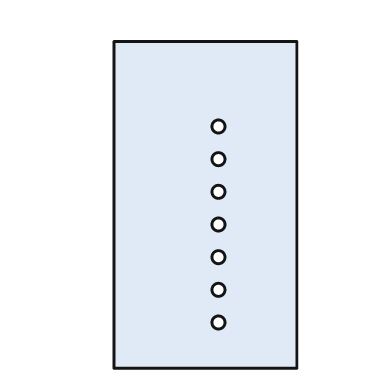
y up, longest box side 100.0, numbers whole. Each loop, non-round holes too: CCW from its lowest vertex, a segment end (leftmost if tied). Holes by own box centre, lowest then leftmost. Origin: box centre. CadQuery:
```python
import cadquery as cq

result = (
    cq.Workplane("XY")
    .moveTo(-28.0, -50.0)
    .lineTo(28.0, -50.0)
    .lineTo(28.0, 50.0)
    .lineTo(-28.0, 50.0)
    .close()
    .moveTo(4.0, -36.0)
    .circle(2.0)
    .moveTo(4.0, -26.0)
    .circle(2.0)
    .moveTo(4.0, -16.0)
    .circle(2.0)
    .moveTo(4.0, -6.0)
    .circle(2.0)
    .moveTo(4.0, 4.0)
    .circle(2.0)
    .moveTo(4.0, 14.0)
    .circle(2.0)
    .moveTo(4.0, 24.0)
    .circle(2.0)
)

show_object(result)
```